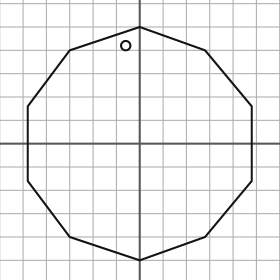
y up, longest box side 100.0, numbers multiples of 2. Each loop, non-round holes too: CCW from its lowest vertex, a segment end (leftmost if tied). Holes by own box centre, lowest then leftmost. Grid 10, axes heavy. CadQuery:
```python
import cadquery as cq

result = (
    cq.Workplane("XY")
    .moveTo(0.0, -50.0)
    .lineTo(28.0, -40.0)
    .lineTo(48.0, -16.0)
    .lineTo(48.0, 16.0)
    .lineTo(28.0, 40.0)
    .lineTo(0.0, 50.0)
    .lineTo(-30.0, 40.0)
    .lineTo(-48.0, 16.0)
    .lineTo(-48.0, -16.0)
    .lineTo(-30.0, -40.0)
    .close()
    .moveTo(-6.0, 42.0)
    .circle(2.0)
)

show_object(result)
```